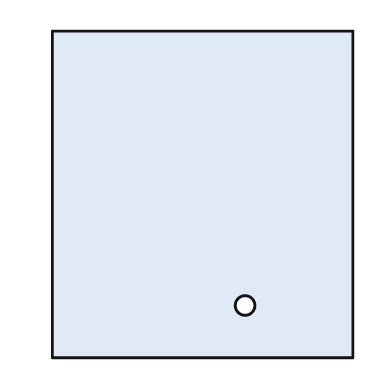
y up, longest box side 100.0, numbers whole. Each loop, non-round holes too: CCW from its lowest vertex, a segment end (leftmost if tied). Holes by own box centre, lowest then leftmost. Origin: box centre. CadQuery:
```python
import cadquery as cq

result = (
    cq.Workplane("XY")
    .moveTo(-46.0, -50.0)
    .lineTo(46.0, -50.0)
    .lineTo(46.0, 50.0)
    .lineTo(-46.0, 50.0)
    .close()
    .moveTo(13.0, -34.0)
    .circle(3.0)
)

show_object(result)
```